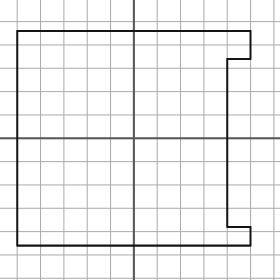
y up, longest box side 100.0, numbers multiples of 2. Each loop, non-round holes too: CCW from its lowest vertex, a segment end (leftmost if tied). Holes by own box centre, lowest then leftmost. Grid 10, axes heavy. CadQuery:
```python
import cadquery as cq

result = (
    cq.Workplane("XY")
    .moveTo(-50.0, -46.0)
    .lineTo(50.0, -46.0)
    .lineTo(50.0, -38.0)
    .lineTo(40.0, -38.0)
    .lineTo(40.0, 34.0)
    .lineTo(50.0, 34.0)
    .lineTo(50.0, 46.0)
    .lineTo(-50.0, 46.0)
    .close()
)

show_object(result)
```